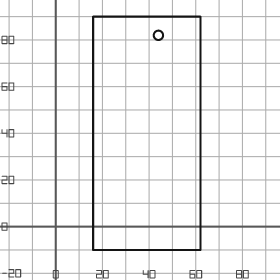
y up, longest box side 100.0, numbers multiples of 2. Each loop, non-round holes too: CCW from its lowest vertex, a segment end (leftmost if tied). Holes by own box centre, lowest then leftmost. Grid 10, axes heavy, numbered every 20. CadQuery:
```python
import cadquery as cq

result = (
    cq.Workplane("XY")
    .moveTo(16.0, -10.0)
    .lineTo(62.0, -10.0)
    .lineTo(62.0, 90.0)
    .lineTo(16.0, 90.0)
    .close()
    .moveTo(44.0, 82.0)
    .circle(2.0)
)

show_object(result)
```